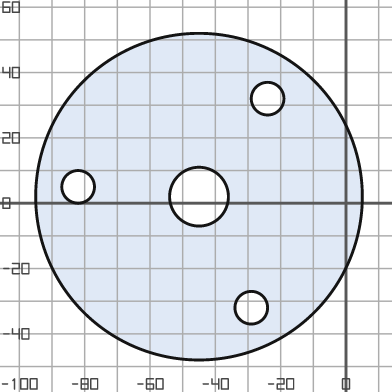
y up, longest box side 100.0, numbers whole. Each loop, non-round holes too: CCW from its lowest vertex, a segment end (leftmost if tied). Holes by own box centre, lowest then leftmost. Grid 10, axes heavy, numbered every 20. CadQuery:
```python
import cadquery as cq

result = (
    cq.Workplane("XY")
    .moveTo(-45.0, 2.0)
    .circle(50.0)
    .moveTo(-29.0, -32.0)
    .circle(5.0)
    .moveTo(-45.0, 2.0)
    .circle(9.0)
    .moveTo(-82.0, 5.0)
    .circle(5.0)
    .moveTo(-24.0, 32.0)
    .circle(5.0)
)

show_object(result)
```